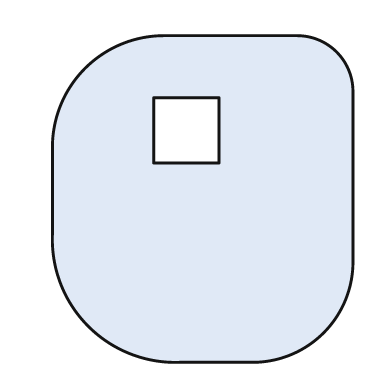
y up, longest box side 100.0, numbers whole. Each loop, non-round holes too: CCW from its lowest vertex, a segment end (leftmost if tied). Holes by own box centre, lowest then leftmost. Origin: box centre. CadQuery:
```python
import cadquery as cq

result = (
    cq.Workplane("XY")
    .moveTo(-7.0, -50.0)
    .lineTo(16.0, -50.0)
    .threePointArc((37.0, -41.0), (46.0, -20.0))
    .lineTo(46.0, 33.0)
    .threePointArc((41.0, 45.0), (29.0, 50.0))
    .lineTo(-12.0, 50.0)
    .threePointArc((-36.0, 40.0), (-46.0, 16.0))
    .lineTo(-46.0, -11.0)
    .threePointArc((-35.0, -39.0), (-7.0, -50.0))
    .close()
    .moveTo(-15.0, 11.0)
    .lineTo(5.0, 11.0)
    .lineTo(5.0, 31.0)
    .lineTo(-15.0, 31.0)
    .close()
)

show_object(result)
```